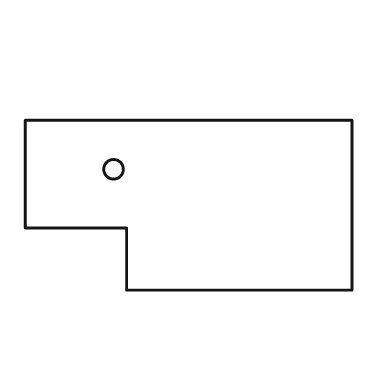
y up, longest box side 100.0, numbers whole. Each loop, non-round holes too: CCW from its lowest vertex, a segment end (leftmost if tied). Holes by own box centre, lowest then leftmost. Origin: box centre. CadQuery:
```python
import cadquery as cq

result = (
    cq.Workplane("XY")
    .moveTo(-19.0, -26.0)
    .lineTo(50.0, -26.0)
    .lineTo(50.0, 26.0)
    .lineTo(-50.0, 26.0)
    .lineTo(-50.0, -7.0)
    .lineTo(-19.0, -7.0)
    .close()
    .moveTo(-23.0, 11.0)
    .circle(3.0)
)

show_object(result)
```